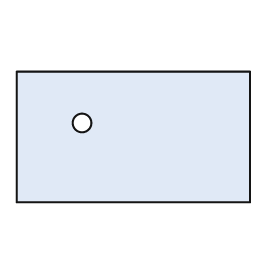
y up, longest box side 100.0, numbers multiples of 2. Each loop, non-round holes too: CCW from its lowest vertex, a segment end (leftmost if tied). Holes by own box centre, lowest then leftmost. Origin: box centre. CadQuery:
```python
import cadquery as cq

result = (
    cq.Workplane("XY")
    .moveTo(-50.0, -28.0)
    .lineTo(50.0, -28.0)
    .lineTo(50.0, 28.0)
    .lineTo(-50.0, 28.0)
    .close()
    .moveTo(-22.0, 6.0)
    .circle(4.0)
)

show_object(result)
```